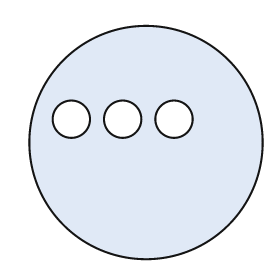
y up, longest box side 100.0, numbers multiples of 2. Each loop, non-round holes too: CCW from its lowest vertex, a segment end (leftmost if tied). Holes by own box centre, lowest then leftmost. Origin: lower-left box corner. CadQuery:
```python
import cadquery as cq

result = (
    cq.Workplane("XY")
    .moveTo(50.0, 50.0)
    .circle(50.0)
    .moveTo(18.0, 60.0)
    .circle(8.0)
    .moveTo(40.0, 60.0)
    .circle(8.0)
    .moveTo(62.0, 60.0)
    .circle(8.0)
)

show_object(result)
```